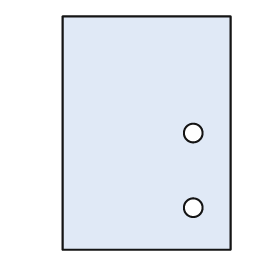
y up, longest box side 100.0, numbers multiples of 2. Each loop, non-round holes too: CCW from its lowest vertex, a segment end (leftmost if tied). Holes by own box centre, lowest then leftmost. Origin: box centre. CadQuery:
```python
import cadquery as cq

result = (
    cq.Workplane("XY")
    .moveTo(-36.0, -50.0)
    .lineTo(36.0, -50.0)
    .lineTo(36.0, 50.0)
    .lineTo(-36.0, 50.0)
    .close()
    .moveTo(20.0, -32.0)
    .circle(4.0)
    .moveTo(20.0, 0.0)
    .circle(4.0)
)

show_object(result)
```